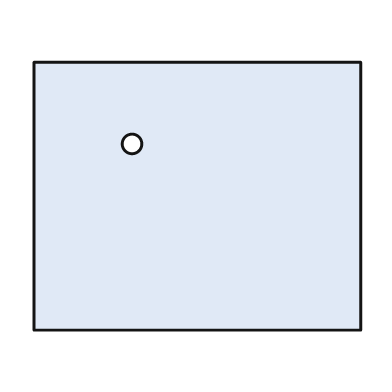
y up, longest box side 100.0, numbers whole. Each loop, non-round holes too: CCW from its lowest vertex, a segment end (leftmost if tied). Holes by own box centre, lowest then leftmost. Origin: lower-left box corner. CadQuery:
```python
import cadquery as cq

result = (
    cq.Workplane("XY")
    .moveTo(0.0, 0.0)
    .lineTo(100.0, 0.0)
    .lineTo(100.0, 82.0)
    .lineTo(0.0, 82.0)
    .close()
    .moveTo(30.0, 57.0)
    .circle(3.0)
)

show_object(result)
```